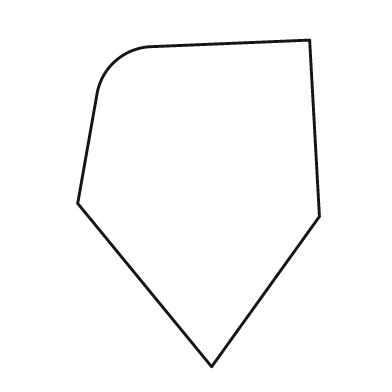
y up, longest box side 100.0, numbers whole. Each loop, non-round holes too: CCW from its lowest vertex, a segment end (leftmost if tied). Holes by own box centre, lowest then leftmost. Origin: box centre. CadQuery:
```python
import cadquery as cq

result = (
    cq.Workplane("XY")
    .moveTo(4.0, -50.0)
    .lineTo(37.0, -4.0)
    .lineTo(34.0, 50.0)
    .lineTo(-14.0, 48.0)
    .threePointArc((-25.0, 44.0), (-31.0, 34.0))
    .lineTo(-37.0, 0.0)
    .close()
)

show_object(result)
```